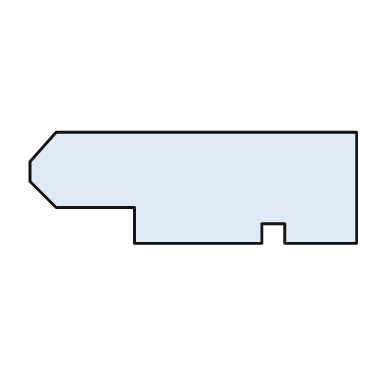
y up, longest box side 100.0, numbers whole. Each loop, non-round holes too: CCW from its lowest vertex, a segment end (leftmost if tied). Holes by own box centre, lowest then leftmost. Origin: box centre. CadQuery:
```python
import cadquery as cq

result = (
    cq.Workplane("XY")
    .moveTo(-18.0, -17.0)
    .lineTo(21.0, -17.0)
    .lineTo(21.0, -11.0)
    .lineTo(28.0, -11.0)
    .lineTo(28.0, -17.0)
    .lineTo(50.0, -17.0)
    .lineTo(50.0, 17.0)
    .lineTo(-42.0, 17.0)
    .lineTo(-50.0, 8.0)
    .lineTo(-50.0, 2.0)
    .lineTo(-42.0, -6.0)
    .lineTo(-18.0, -6.0)
    .close()
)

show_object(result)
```